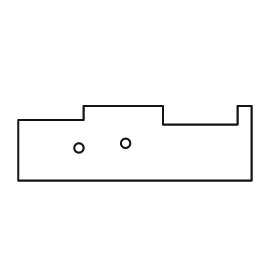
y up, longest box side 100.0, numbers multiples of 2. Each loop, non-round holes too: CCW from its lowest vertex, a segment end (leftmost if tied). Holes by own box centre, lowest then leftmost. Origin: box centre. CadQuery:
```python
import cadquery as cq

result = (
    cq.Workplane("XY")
    .moveTo(-50.0, -16.0)
    .lineTo(50.0, -16.0)
    .lineTo(50.0, 16.0)
    .lineTo(44.0, 16.0)
    .lineTo(44.0, 8.0)
    .lineTo(12.0, 8.0)
    .lineTo(12.0, 16.0)
    .lineTo(-22.0, 16.0)
    .lineTo(-22.0, 10.0)
    .lineTo(-50.0, 10.0)
    .close()
    .moveTo(-24.0, -2.0)
    .circle(2.0)
    .moveTo(-4.0, 0.0)
    .circle(2.0)
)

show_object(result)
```